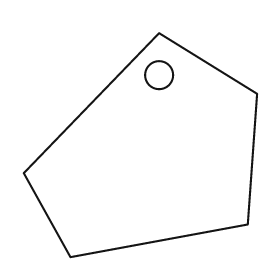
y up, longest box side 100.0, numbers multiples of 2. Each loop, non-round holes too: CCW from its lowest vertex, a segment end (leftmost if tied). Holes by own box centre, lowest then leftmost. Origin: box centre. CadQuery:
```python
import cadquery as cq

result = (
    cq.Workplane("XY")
    .moveTo(-30.0, -48.0)
    .lineTo(46.0, -34.0)
    .lineTo(50.0, 22.0)
    .lineTo(8.0, 48.0)
    .lineTo(-50.0, -12.0)
    .close()
    .moveTo(8.0, 30.0)
    .circle(6.0)
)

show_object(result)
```